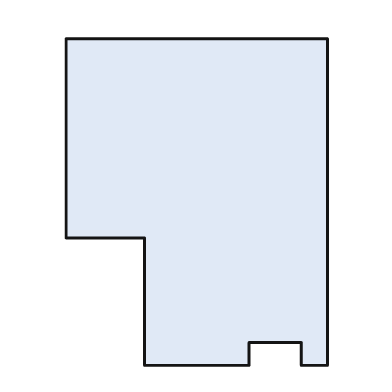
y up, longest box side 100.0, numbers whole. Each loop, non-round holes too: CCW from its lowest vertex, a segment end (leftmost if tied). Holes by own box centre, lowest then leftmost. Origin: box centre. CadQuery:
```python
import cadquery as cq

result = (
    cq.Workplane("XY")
    .moveTo(-16.0, -50.0)
    .lineTo(16.0, -50.0)
    .lineTo(16.0, -43.0)
    .lineTo(32.0, -43.0)
    .lineTo(32.0, -50.0)
    .lineTo(40.0, -50.0)
    .lineTo(40.0, 50.0)
    .lineTo(-40.0, 50.0)
    .lineTo(-40.0, -11.0)
    .lineTo(-16.0, -11.0)
    .close()
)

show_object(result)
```